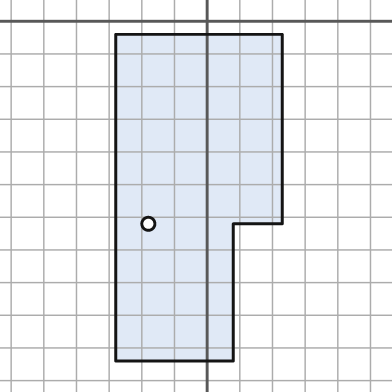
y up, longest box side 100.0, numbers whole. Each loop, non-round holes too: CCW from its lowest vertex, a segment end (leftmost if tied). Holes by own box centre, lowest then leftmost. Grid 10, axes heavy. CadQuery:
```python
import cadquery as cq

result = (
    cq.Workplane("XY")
    .moveTo(-28.0, -104.0)
    .lineTo(8.0, -104.0)
    .lineTo(8.0, -62.0)
    .lineTo(23.0, -62.0)
    .lineTo(23.0, -4.0)
    .lineTo(-28.0, -4.0)
    .close()
    .moveTo(-18.0, -62.0)
    .circle(2.0)
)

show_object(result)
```